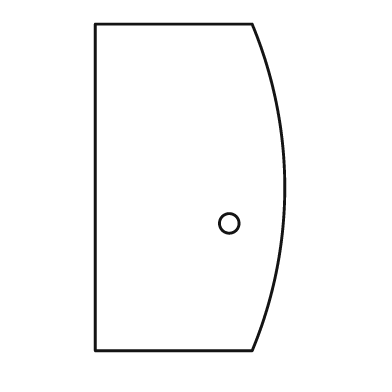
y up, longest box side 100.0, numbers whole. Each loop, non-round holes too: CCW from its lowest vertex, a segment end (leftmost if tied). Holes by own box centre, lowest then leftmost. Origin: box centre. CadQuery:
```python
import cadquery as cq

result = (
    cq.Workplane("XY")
    .moveTo(-29.0, -50.0)
    .lineTo(19.0, -50.0)
    .threePointArc((29.0, 0.0), (19.0, 50.0))
    .lineTo(-29.0, 50.0)
    .close()
    .moveTo(12.0, -11.0)
    .circle(3.0)
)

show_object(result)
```